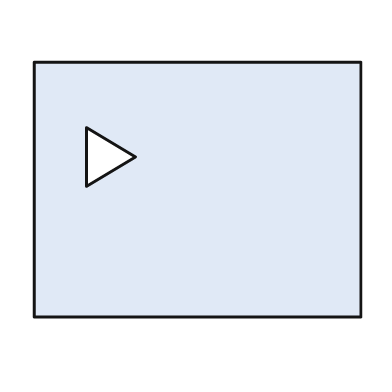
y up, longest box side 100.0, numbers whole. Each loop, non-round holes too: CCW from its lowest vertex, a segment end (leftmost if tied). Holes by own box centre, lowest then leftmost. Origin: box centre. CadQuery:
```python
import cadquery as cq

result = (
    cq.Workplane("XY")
    .moveTo(-50.0, -39.0)
    .lineTo(50.0, -39.0)
    .lineTo(50.0, 39.0)
    .lineTo(-50.0, 39.0)
    .close()
    .moveTo(-34.0, 1.0)
    .lineTo(-19.0, 10.0)
    .lineTo(-34.0, 19.0)
    .close()
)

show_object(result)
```